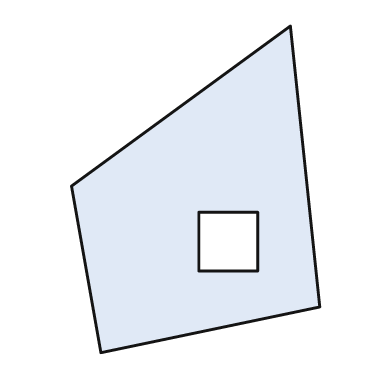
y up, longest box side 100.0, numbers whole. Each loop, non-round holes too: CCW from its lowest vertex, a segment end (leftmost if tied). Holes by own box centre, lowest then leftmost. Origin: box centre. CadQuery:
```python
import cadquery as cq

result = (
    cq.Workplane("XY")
    .moveTo(-29.0, -50.0)
    .lineTo(38.0, -36.0)
    .lineTo(29.0, 50.0)
    .lineTo(-38.0, 1.0)
    .close()
    .moveTo(1.0, -25.0)
    .lineTo(19.0, -25.0)
    .lineTo(19.0, -7.0)
    .lineTo(1.0, -7.0)
    .close()
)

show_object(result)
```